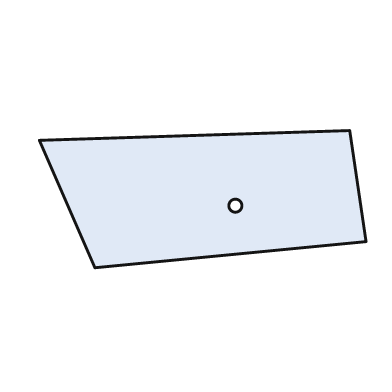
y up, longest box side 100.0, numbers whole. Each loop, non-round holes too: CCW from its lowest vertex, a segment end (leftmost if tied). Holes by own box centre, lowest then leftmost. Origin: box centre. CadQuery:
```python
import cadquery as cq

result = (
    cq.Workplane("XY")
    .moveTo(-33.0, -21.0)
    .lineTo(50.0, -13.0)
    .lineTo(45.0, 21.0)
    .lineTo(-50.0, 18.0)
    .close()
    .moveTo(10.0, -2.0)
    .circle(2.0)
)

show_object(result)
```